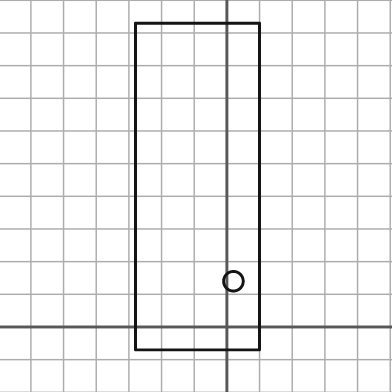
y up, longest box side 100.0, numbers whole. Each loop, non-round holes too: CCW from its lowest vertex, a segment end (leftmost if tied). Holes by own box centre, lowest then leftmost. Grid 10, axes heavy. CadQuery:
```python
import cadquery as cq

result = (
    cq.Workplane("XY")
    .moveTo(-28.0, -7.0)
    .lineTo(10.0, -7.0)
    .lineTo(10.0, 93.0)
    .lineTo(-28.0, 93.0)
    .close()
    .moveTo(2.0, 14.0)
    .circle(3.0)
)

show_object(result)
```